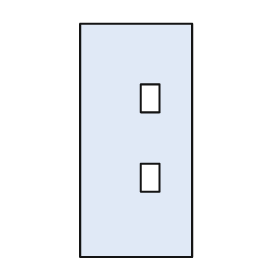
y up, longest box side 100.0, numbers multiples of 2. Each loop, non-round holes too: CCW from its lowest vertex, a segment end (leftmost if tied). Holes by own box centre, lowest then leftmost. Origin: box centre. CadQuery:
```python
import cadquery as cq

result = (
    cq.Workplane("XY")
    .moveTo(-24.0, -50.0)
    .lineTo(24.0, -50.0)
    .lineTo(24.0, 50.0)
    .lineTo(-24.0, 50.0)
    .close()
    .moveTo(2.0, -22.0)
    .lineTo(10.0, -22.0)
    .lineTo(10.0, -10.0)
    .lineTo(2.0, -10.0)
    .close()
    .moveTo(2.0, 12.0)
    .lineTo(10.0, 12.0)
    .lineTo(10.0, 24.0)
    .lineTo(2.0, 24.0)
    .close()
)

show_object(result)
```